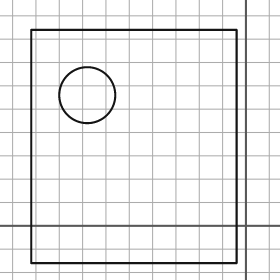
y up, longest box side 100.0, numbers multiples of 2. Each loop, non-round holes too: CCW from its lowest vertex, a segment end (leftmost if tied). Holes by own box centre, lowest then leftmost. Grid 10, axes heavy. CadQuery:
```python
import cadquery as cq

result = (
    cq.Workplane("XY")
    .moveTo(-92.0, -16.0)
    .lineTo(-4.0, -16.0)
    .lineTo(-4.0, 84.0)
    .lineTo(-92.0, 84.0)
    .close()
    .moveTo(-68.0, 56.0)
    .circle(12.0)
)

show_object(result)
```